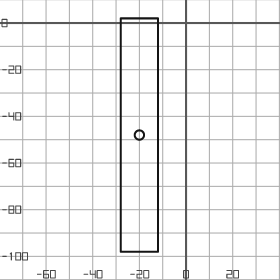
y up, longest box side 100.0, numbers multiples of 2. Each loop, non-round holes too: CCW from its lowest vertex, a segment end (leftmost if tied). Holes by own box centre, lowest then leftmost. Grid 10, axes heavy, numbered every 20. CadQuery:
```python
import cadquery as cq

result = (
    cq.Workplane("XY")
    .moveTo(-28.0, -98.0)
    .lineTo(-12.0, -98.0)
    .lineTo(-12.0, 2.0)
    .lineTo(-28.0, 2.0)
    .close()
    .moveTo(-20.0, -48.0)
    .circle(2.0)
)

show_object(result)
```